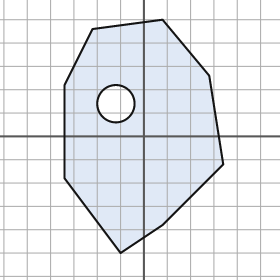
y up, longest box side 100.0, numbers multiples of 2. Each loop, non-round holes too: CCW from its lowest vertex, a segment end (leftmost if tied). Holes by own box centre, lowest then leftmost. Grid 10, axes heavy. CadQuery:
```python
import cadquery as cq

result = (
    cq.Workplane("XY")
    .moveTo(-10.0, -50.0)
    .lineTo(8.0, -38.0)
    .lineTo(34.0, -12.0)
    .lineTo(28.0, 26.0)
    .lineTo(8.0, 50.0)
    .lineTo(-22.0, 46.0)
    .lineTo(-34.0, 22.0)
    .lineTo(-34.0, -18.0)
    .close()
    .moveTo(-12.0, 14.0)
    .circle(8.0)
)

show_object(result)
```